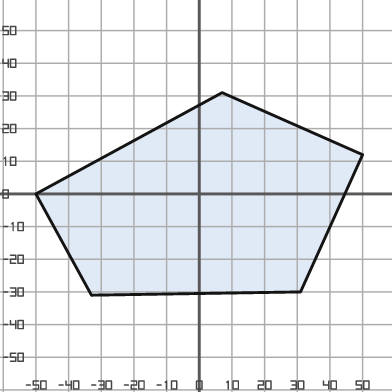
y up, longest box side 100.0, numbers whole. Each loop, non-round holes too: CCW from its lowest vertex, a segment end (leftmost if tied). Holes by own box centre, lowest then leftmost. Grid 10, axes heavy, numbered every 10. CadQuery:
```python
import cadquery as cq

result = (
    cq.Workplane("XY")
    .moveTo(-33.0, -31.0)
    .lineTo(31.0, -30.0)
    .lineTo(50.0, 12.0)
    .lineTo(7.0, 31.0)
    .lineTo(-50.0, 0.0)
    .close()
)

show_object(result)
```